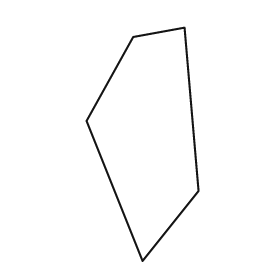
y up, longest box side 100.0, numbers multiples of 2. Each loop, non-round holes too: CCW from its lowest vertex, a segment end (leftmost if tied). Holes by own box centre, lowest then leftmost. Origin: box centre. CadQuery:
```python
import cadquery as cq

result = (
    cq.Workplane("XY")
    .moveTo(0.0, -50.0)
    .lineTo(24.0, -20.0)
    .lineTo(18.0, 50.0)
    .lineTo(-4.0, 46.0)
    .lineTo(-24.0, 10.0)
    .close()
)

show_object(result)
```